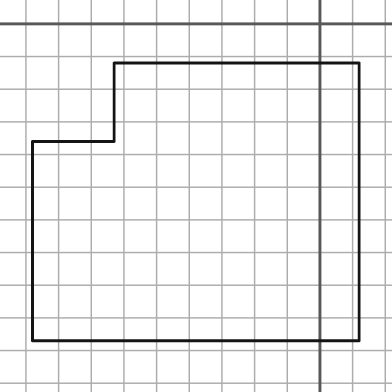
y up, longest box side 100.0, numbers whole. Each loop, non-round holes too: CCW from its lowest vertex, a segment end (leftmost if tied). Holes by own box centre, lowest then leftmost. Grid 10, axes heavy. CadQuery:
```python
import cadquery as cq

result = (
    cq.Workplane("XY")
    .moveTo(-88.0, -97.0)
    .lineTo(12.0, -97.0)
    .lineTo(12.0, -12.0)
    .lineTo(-63.0, -12.0)
    .lineTo(-63.0, -36.0)
    .lineTo(-88.0, -36.0)
    .close()
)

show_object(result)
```